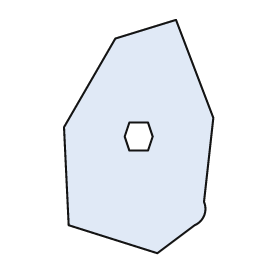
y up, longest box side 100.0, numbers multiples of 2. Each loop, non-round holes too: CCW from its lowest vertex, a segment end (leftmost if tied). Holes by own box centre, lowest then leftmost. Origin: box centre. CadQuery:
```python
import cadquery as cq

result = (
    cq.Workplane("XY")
    .moveTo(8.0, -50.0)
    .lineTo(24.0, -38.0)
    .threePointArc((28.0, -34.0), (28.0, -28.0))
    .lineTo(32.0, 8.0)
    .lineTo(16.0, 50.0)
    .lineTo(-10.0, 42.0)
    .lineTo(-32.0, 4.0)
    .lineTo(-30.0, -38.0)
    .close()
    .moveTo(-4.0, -6.0)
    .lineTo(4.0, -6.0)
    .lineTo(6.0, 0.0)
    .lineTo(4.0, 6.0)
    .lineTo(-4.0, 6.0)
    .lineTo(-6.0, 0.0)
    .close()
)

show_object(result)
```